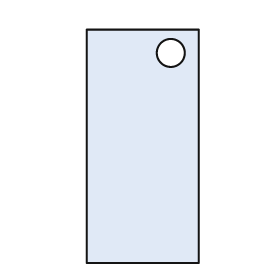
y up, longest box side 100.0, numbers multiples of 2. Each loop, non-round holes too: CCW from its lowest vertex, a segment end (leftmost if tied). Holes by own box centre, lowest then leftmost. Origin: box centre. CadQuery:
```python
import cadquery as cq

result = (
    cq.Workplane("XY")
    .moveTo(-24.0, -50.0)
    .lineTo(24.0, -50.0)
    .lineTo(24.0, 50.0)
    .lineTo(-24.0, 50.0)
    .close()
    .moveTo(12.0, 40.0)
    .circle(6.0)
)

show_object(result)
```